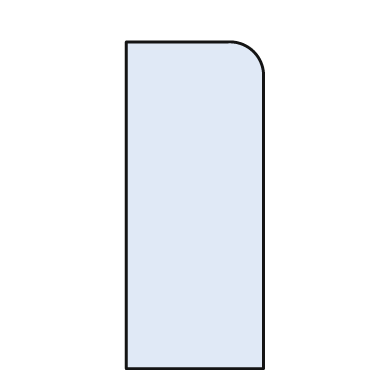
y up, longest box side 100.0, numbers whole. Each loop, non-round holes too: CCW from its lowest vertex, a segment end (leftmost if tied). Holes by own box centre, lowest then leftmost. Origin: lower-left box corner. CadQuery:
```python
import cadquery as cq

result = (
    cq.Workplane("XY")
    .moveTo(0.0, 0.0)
    .lineTo(42.0, 0.0)
    .lineTo(42.0, 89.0)
    .threePointArc((39.0, 97.0), (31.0, 100.0))
    .lineTo(0.0, 100.0)
    .close()
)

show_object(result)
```